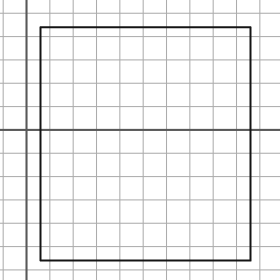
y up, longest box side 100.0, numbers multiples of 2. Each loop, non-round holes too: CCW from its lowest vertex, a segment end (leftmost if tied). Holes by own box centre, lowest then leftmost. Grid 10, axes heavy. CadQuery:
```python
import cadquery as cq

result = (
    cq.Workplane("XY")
    .moveTo(6.0, -56.0)
    .lineTo(96.0, -56.0)
    .lineTo(96.0, 44.0)
    .lineTo(6.0, 44.0)
    .close()
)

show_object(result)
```